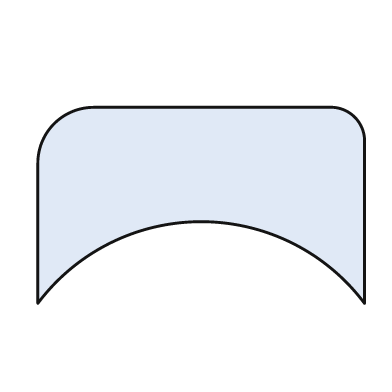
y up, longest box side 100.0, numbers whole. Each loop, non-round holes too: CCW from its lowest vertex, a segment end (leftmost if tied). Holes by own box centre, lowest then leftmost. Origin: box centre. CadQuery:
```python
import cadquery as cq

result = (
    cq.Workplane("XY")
    .moveTo(-50.0, -30.0)
    .threePointArc((0.0, -5.0), (50.0, -30.0))
    .lineTo(50.0, 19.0)
    .threePointArc((47.0, 27.0), (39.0, 30.0))
    .lineTo(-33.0, 30.0)
    .threePointArc((-45.0, 25.0), (-50.0, 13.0))
    .close()
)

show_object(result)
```